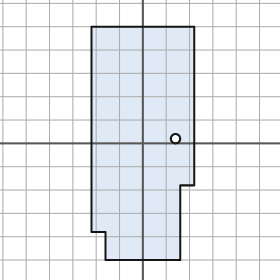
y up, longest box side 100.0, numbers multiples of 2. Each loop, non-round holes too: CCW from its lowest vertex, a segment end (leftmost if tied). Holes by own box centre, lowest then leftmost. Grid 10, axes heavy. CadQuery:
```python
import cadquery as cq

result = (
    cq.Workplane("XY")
    .moveTo(-16.0, -50.0)
    .lineTo(16.0, -50.0)
    .lineTo(16.0, -18.0)
    .lineTo(22.0, -18.0)
    .lineTo(22.0, 50.0)
    .lineTo(-22.0, 50.0)
    .lineTo(-22.0, -38.0)
    .lineTo(-16.0, -38.0)
    .close()
    .moveTo(14.0, 2.0)
    .circle(2.0)
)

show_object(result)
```